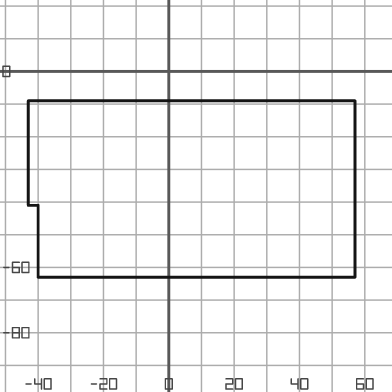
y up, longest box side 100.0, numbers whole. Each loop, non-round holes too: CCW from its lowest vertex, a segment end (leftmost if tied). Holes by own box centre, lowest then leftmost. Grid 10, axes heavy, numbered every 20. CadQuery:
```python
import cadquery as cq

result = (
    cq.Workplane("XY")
    .moveTo(-40.0, -63.0)
    .lineTo(57.0, -63.0)
    .lineTo(57.0, -9.0)
    .lineTo(-43.0, -9.0)
    .lineTo(-43.0, -41.0)
    .lineTo(-40.0, -41.0)
    .close()
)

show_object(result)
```